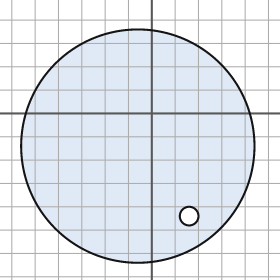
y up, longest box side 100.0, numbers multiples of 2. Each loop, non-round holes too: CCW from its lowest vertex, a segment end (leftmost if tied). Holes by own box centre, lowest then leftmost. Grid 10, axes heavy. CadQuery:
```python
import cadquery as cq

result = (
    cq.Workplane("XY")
    .moveTo(-6.0, -14.0)
    .circle(50.0)
    .moveTo(16.0, -44.0)
    .circle(4.0)
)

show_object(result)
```